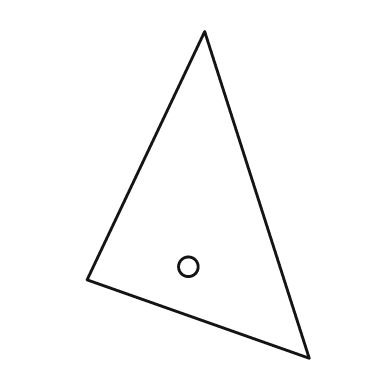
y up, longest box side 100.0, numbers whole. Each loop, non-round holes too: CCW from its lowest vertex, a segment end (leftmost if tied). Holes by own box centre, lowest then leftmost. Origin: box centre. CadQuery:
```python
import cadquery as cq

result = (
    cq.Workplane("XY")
    .moveTo(34.0, -50.0)
    .lineTo(2.0, 50.0)
    .lineTo(-34.0, -26.0)
    .close()
    .moveTo(-3.0, -22.0)
    .circle(3.0)
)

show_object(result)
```